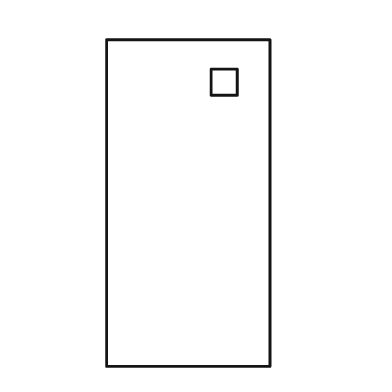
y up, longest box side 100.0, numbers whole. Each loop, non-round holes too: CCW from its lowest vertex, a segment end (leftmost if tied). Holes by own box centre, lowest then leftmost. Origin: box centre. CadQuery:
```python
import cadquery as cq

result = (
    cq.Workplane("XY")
    .moveTo(-25.0, -50.0)
    .lineTo(25.0, -50.0)
    .lineTo(25.0, 50.0)
    .lineTo(-25.0, 50.0)
    .close()
    .moveTo(7.0, 33.0)
    .lineTo(15.0, 33.0)
    .lineTo(15.0, 41.0)
    .lineTo(7.0, 41.0)
    .close()
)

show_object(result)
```